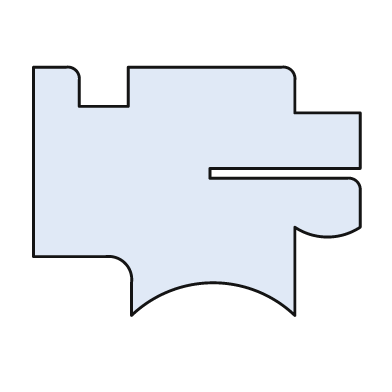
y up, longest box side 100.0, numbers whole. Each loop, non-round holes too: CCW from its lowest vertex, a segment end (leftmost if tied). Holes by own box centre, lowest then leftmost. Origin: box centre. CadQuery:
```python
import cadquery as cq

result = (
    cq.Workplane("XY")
    .moveTo(-20.0, -38.0)
    .threePointArc((5.0, -28.0), (30.0, -38.0))
    .lineTo(30.0, -11.0)
    .threePointArc((40.0, -14.0), (50.0, -11.0))
    .lineTo(50.0, 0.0)
    .threePointArc((49.0, 3.0), (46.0, 4.0))
    .lineTo(4.0, 4.0)
    .lineTo(4.0, 7.0)
    .lineTo(50.0, 7.0)
    .lineTo(50.0, 24.0)
    .lineTo(30.0, 24.0)
    .lineTo(30.0, 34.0)
    .threePointArc((29.0, 37.0), (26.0, 38.0))
    .lineTo(-21.0, 38.0)
    .lineTo(-21.0, 26.0)
    .lineTo(-36.0, 26.0)
    .lineTo(-36.0, 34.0)
    .threePointArc((-37.0, 37.0), (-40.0, 38.0))
    .lineTo(-50.0, 38.0)
    .lineTo(-50.0, -20.0)
    .lineTo(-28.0, -20.0)
    .threePointArc((-22.0, -22.0), (-20.0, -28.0))
    .close()
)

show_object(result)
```